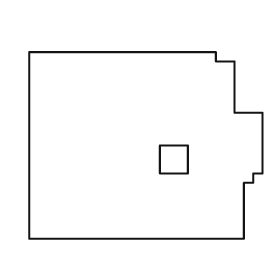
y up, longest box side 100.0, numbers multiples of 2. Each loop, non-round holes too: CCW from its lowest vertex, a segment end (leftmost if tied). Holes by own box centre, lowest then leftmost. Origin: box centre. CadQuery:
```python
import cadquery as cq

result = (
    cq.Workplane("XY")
    .moveTo(-50.0, -40.0)
    .lineTo(42.0, -40.0)
    .lineTo(42.0, -16.0)
    .lineTo(46.0, -16.0)
    .lineTo(46.0, -12.0)
    .lineTo(50.0, -12.0)
    .lineTo(50.0, 14.0)
    .lineTo(38.0, 14.0)
    .lineTo(38.0, 36.0)
    .lineTo(30.0, 36.0)
    .lineTo(30.0, 40.0)
    .lineTo(-50.0, 40.0)
    .close()
    .moveTo(6.0, -12.0)
    .lineTo(18.0, -12.0)
    .lineTo(18.0, 0.0)
    .lineTo(6.0, 0.0)
    .close()
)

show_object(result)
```